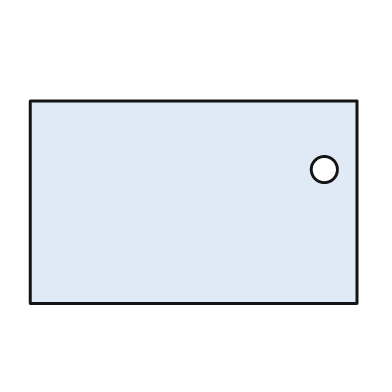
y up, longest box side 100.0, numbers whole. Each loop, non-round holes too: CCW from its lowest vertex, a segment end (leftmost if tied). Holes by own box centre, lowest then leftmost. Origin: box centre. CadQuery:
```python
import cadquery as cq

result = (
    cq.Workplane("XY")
    .moveTo(-50.0, -31.0)
    .lineTo(50.0, -31.0)
    .lineTo(50.0, 31.0)
    .lineTo(-50.0, 31.0)
    .close()
    .moveTo(40.0, 10.0)
    .circle(4.0)
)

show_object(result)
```